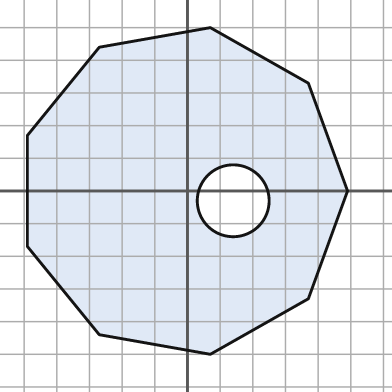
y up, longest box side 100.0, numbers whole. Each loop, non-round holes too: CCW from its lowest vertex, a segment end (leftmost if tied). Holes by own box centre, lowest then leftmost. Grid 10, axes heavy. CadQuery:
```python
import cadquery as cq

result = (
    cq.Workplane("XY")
    .moveTo(7.0, -50.0)
    .lineTo(37.0, -33.0)
    .lineTo(49.0, 0.0)
    .lineTo(37.0, 33.0)
    .lineTo(7.0, 50.0)
    .lineTo(-27.0, 44.0)
    .lineTo(-49.0, 17.0)
    .lineTo(-49.0, -17.0)
    .lineTo(-27.0, -44.0)
    .close()
    .moveTo(14.0, -3.0)
    .circle(11.0)
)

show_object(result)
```